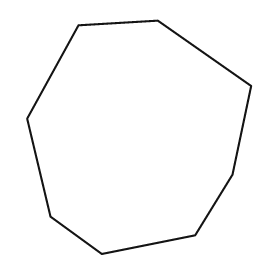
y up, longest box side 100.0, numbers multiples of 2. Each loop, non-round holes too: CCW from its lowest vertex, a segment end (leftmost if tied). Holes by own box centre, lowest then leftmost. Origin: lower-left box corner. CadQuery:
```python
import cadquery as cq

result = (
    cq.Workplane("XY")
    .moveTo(32.0, 0.0)
    .lineTo(72.0, 8.0)
    .lineTo(88.0, 34.0)
    .lineTo(96.0, 72.0)
    .lineTo(56.0, 100.0)
    .lineTo(22.0, 98.0)
    .lineTo(0.0, 58.0)
    .lineTo(10.0, 16.0)
    .close()
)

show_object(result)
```